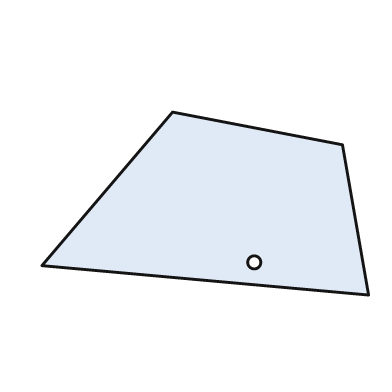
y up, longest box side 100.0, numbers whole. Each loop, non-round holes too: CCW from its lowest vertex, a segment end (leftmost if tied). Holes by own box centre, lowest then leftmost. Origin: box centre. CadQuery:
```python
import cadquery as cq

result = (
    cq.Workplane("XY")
    .moveTo(50.0, -28.0)
    .lineTo(42.0, 18.0)
    .lineTo(-10.0, 28.0)
    .lineTo(-50.0, -19.0)
    .close()
    .moveTo(15.0, -18.0)
    .circle(2.0)
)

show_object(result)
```